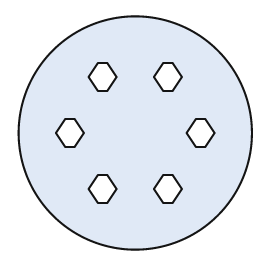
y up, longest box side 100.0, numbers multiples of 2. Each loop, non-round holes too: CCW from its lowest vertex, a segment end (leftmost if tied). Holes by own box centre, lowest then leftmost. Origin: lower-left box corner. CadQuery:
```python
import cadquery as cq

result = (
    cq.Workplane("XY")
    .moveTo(50.0, 50.0)
    .circle(50.0)
    .moveTo(34.0, 20.0)
    .lineTo(38.0, 20.0)
    .lineTo(42.0, 26.0)
    .lineTo(38.0, 32.0)
    .lineTo(34.0, 32.0)
    .lineTo(30.0, 26.0)
    .close()
    .moveTo(62.0, 20.0)
    .lineTo(66.0, 20.0)
    .lineTo(70.0, 26.0)
    .lineTo(66.0, 32.0)
    .lineTo(62.0, 32.0)
    .lineTo(58.0, 26.0)
    .close()
    .moveTo(20.0, 44.0)
    .lineTo(24.0, 44.0)
    .lineTo(28.0, 50.0)
    .lineTo(24.0, 56.0)
    .lineTo(20.0, 56.0)
    .lineTo(16.0, 50.0)
    .close()
    .moveTo(76.0, 44.0)
    .lineTo(80.0, 44.0)
    .lineTo(84.0, 50.0)
    .lineTo(80.0, 56.0)
    .lineTo(76.0, 56.0)
    .lineTo(72.0, 50.0)
    .close()
    .moveTo(34.0, 68.0)
    .lineTo(38.0, 68.0)
    .lineTo(42.0, 74.0)
    .lineTo(38.0, 80.0)
    .lineTo(34.0, 80.0)
    .lineTo(30.0, 74.0)
    .close()
    .moveTo(62.0, 68.0)
    .lineTo(66.0, 68.0)
    .lineTo(70.0, 74.0)
    .lineTo(66.0, 80.0)
    .lineTo(62.0, 80.0)
    .lineTo(58.0, 74.0)
    .close()
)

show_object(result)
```